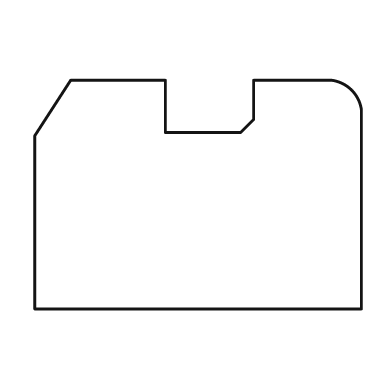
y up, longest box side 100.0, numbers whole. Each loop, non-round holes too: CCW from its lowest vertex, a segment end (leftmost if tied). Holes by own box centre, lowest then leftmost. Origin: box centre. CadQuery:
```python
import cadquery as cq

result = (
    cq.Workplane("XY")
    .moveTo(-50.0, -35.0)
    .lineTo(50.0, -35.0)
    .lineTo(50.0, 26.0)
    .threePointArc((47.0, 32.0), (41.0, 35.0))
    .lineTo(17.0, 35.0)
    .lineTo(17.0, 23.0)
    .lineTo(13.0, 19.0)
    .lineTo(-10.0, 19.0)
    .lineTo(-10.0, 35.0)
    .lineTo(-39.0, 35.0)
    .lineTo(-50.0, 18.0)
    .close()
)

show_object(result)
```